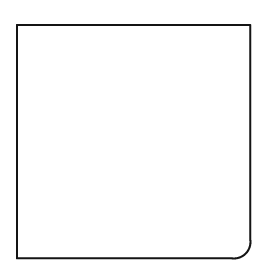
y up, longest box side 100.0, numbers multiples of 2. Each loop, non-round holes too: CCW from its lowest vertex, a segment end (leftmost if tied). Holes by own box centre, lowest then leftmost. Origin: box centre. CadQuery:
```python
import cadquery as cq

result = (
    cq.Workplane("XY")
    .moveTo(-50.0, -50.0)
    .lineTo(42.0, -50.0)
    .threePointArc((48.0, -48.0), (50.0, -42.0))
    .lineTo(50.0, 50.0)
    .lineTo(-50.0, 50.0)
    .close()
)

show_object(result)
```